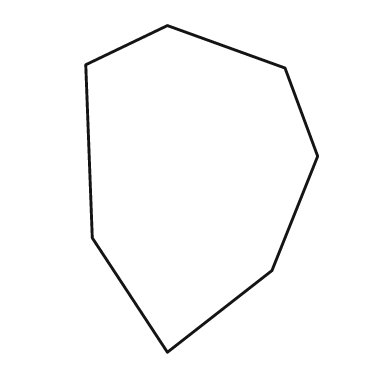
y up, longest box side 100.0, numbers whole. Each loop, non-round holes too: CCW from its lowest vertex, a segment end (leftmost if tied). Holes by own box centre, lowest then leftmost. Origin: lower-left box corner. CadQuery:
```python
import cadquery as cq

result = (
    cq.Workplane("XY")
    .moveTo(25.0, 0.0)
    .lineTo(57.0, 25.0)
    .lineTo(71.0, 60.0)
    .lineTo(61.0, 87.0)
    .lineTo(25.0, 100.0)
    .lineTo(0.0, 88.0)
    .lineTo(2.0, 35.0)
    .close()
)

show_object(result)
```